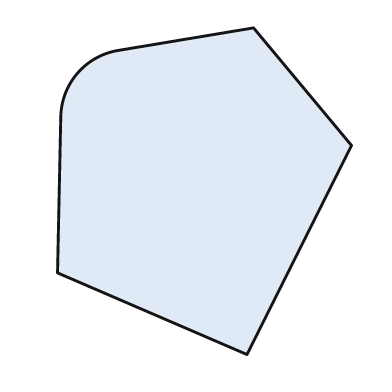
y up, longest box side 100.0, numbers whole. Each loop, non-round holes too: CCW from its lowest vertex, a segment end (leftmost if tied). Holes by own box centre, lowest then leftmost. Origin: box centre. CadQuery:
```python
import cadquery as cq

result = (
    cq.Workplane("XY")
    .moveTo(13.0, -50.0)
    .lineTo(45.0, 14.0)
    .lineTo(15.0, 50.0)
    .lineTo(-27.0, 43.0)
    .threePointArc((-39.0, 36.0), (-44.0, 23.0))
    .lineTo(-45.0, -25.0)
    .close()
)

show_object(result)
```